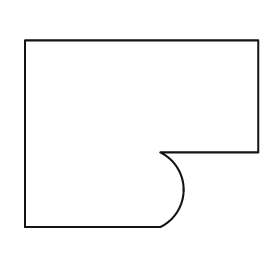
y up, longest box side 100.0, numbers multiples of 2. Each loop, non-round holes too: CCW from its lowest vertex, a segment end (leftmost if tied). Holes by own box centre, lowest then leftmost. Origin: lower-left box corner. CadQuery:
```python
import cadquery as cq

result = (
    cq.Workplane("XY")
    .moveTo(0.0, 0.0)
    .lineTo(58.0, 0.0)
    .threePointArc((68.0, 16.0), (58.0, 32.0))
    .lineTo(100.0, 32.0)
    .lineTo(100.0, 80.0)
    .lineTo(0.0, 80.0)
    .close()
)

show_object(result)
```